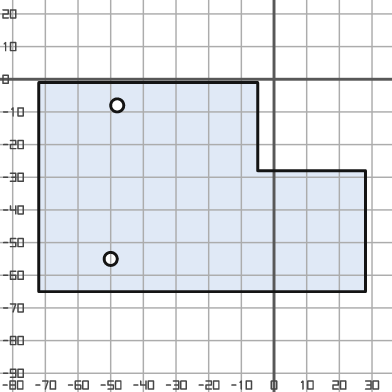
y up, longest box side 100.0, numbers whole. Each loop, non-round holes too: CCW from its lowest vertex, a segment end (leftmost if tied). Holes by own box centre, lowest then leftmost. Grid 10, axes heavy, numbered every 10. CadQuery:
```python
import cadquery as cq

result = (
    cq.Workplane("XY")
    .moveTo(-72.0, -65.0)
    .lineTo(28.0, -65.0)
    .lineTo(28.0, -28.0)
    .lineTo(-5.0, -28.0)
    .lineTo(-5.0, -1.0)
    .lineTo(-72.0, -1.0)
    .close()
    .moveTo(-50.0, -55.0)
    .circle(2.0)
    .moveTo(-48.0, -8.0)
    .circle(2.0)
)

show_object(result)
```